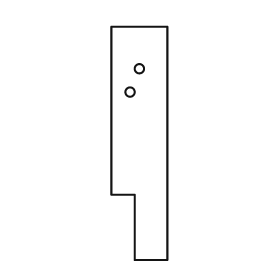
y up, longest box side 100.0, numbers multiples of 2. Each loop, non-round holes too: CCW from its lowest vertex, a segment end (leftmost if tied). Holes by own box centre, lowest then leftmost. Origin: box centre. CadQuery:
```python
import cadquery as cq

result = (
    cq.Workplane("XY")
    .moveTo(-2.0, -50.0)
    .lineTo(12.0, -50.0)
    .lineTo(12.0, 50.0)
    .lineTo(-12.0, 50.0)
    .lineTo(-12.0, -22.0)
    .lineTo(-2.0, -22.0)
    .close()
    .moveTo(-4.0, 22.0)
    .circle(2.0)
    .moveTo(0.0, 32.0)
    .circle(2.0)
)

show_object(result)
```